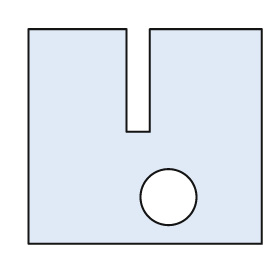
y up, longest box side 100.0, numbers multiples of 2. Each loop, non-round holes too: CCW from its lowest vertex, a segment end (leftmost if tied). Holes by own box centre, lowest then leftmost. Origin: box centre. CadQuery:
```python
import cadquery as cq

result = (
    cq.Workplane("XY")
    .moveTo(-50.0, -46.0)
    .lineTo(50.0, -46.0)
    .lineTo(50.0, 46.0)
    .lineTo(2.0, 46.0)
    .lineTo(2.0, 2.0)
    .lineTo(-8.0, 2.0)
    .lineTo(-8.0, 46.0)
    .lineTo(-50.0, 46.0)
    .close()
    .moveTo(10.0, -26.0)
    .circle(12.0)
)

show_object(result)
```